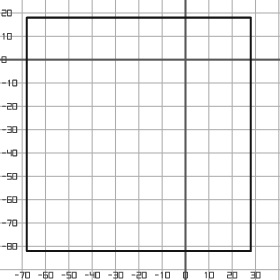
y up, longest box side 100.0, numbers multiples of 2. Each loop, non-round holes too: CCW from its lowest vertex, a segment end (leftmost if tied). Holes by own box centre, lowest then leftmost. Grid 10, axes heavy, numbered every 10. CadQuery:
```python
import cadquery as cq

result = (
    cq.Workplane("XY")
    .moveTo(-68.0, -82.0)
    .lineTo(28.0, -82.0)
    .lineTo(28.0, 18.0)
    .lineTo(-68.0, 18.0)
    .close()
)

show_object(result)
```